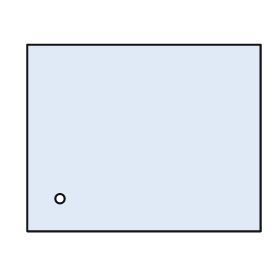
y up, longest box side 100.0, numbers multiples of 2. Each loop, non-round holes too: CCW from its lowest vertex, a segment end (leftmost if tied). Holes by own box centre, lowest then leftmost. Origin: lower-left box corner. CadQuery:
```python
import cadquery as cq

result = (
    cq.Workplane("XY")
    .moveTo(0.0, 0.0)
    .lineTo(100.0, 0.0)
    .lineTo(100.0, 80.0)
    .lineTo(0.0, 80.0)
    .close()
    .moveTo(14.0, 14.0)
    .circle(2.0)
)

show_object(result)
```